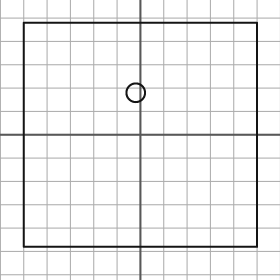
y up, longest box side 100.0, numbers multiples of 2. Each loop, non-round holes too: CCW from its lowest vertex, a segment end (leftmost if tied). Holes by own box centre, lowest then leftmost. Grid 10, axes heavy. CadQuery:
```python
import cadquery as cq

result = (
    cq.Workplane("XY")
    .moveTo(-50.0, -48.0)
    .lineTo(50.0, -48.0)
    .lineTo(50.0, 48.0)
    .lineTo(-50.0, 48.0)
    .close()
    .moveTo(-2.0, 18.0)
    .circle(4.0)
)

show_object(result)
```